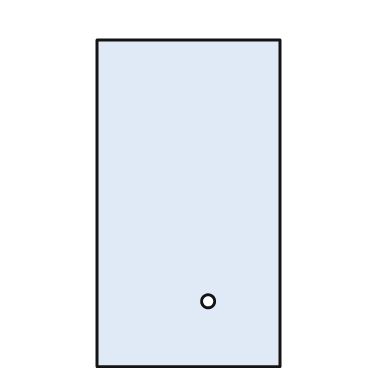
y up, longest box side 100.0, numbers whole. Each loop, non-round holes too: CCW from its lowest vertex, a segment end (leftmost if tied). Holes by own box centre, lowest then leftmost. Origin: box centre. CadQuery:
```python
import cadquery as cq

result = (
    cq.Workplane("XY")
    .moveTo(-28.0, -50.0)
    .lineTo(28.0, -50.0)
    .lineTo(28.0, 50.0)
    .lineTo(-28.0, 50.0)
    .close()
    .moveTo(6.0, -30.0)
    .circle(2.0)
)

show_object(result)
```